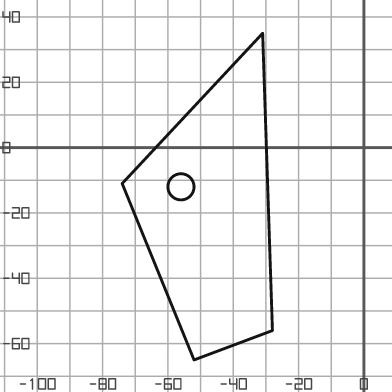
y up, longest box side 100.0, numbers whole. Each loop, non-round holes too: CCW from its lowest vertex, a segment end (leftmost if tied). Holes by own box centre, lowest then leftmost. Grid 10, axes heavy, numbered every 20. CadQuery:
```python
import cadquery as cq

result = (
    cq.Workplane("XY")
    .moveTo(-52.0, -65.0)
    .lineTo(-28.0, -56.0)
    .lineTo(-31.0, 35.0)
    .lineTo(-74.0, -11.0)
    .close()
    .moveTo(-56.0, -12.0)
    .circle(4.0)
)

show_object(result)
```